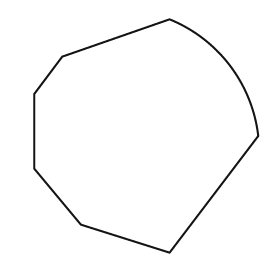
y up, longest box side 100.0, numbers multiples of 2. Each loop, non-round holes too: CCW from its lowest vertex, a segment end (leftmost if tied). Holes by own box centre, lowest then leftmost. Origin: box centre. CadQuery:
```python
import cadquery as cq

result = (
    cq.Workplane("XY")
    .moveTo(10.0, -50.0)
    .lineTo(48.0, 0.0)
    .threePointArc((36.0, 30.0), (10.0, 50.0))
    .lineTo(-36.0, 34.0)
    .lineTo(-48.0, 18.0)
    .lineTo(-48.0, -14.0)
    .lineTo(-28.0, -38.0)
    .close()
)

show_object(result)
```